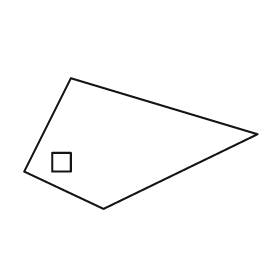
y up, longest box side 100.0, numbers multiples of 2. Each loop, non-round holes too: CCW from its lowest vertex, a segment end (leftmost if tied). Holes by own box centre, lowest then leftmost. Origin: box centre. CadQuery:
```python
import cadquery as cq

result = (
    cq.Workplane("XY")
    .moveTo(-16.0, -28.0)
    .lineTo(50.0, 4.0)
    .lineTo(-30.0, 28.0)
    .lineTo(-50.0, -12.0)
    .close()
    .moveTo(-38.0, -12.0)
    .lineTo(-30.0, -12.0)
    .lineTo(-30.0, -4.0)
    .lineTo(-38.0, -4.0)
    .close()
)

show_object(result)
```